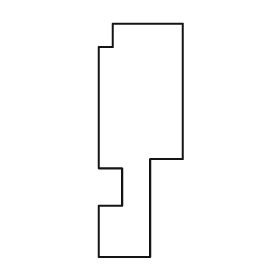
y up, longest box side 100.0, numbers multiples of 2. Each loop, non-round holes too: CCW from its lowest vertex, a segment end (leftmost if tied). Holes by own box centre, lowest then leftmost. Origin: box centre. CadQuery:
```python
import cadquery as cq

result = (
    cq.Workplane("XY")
    .moveTo(-18.0, -50.0)
    .lineTo(4.0, -50.0)
    .lineTo(4.0, -8.0)
    .lineTo(18.0, -8.0)
    .lineTo(18.0, 50.0)
    .lineTo(-12.0, 50.0)
    .lineTo(-12.0, 40.0)
    .lineTo(-18.0, 40.0)
    .lineTo(-18.0, -12.0)
    .lineTo(-8.0, -12.0)
    .lineTo(-8.0, -28.0)
    .lineTo(-18.0, -28.0)
    .close()
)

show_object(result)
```